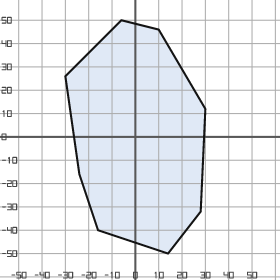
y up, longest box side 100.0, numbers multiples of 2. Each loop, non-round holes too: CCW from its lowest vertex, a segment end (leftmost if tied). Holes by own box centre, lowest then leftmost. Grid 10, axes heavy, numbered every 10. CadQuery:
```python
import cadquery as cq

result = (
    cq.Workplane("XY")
    .moveTo(14.0, -50.0)
    .lineTo(28.0, -32.0)
    .lineTo(30.0, 12.0)
    .lineTo(10.0, 46.0)
    .lineTo(-6.0, 50.0)
    .lineTo(-30.0, 26.0)
    .lineTo(-24.0, -16.0)
    .lineTo(-16.0, -40.0)
    .close()
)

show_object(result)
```